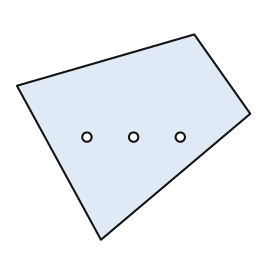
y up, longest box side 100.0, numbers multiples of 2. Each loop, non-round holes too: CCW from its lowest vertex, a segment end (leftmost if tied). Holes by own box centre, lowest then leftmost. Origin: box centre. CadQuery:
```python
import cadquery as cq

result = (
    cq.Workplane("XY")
    .moveTo(-14.0, -44.0)
    .lineTo(50.0, 10.0)
    .lineTo(26.0, 44.0)
    .lineTo(-50.0, 22.0)
    .close()
    .moveTo(-20.0, 0.0)
    .circle(2.0)
    .moveTo(0.0, 0.0)
    .circle(2.0)
    .moveTo(20.0, 0.0)
    .circle(2.0)
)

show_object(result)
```